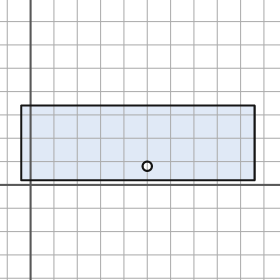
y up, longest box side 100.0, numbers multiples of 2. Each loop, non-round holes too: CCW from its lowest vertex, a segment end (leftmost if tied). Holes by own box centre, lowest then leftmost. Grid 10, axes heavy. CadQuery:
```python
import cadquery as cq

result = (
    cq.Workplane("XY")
    .moveTo(-4.0, 2.0)
    .lineTo(96.0, 2.0)
    .lineTo(96.0, 34.0)
    .lineTo(-4.0, 34.0)
    .close()
    .moveTo(50.0, 8.0)
    .circle(2.0)
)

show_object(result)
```